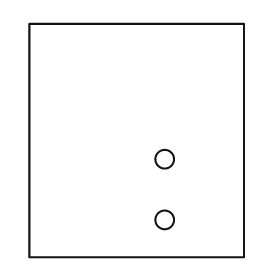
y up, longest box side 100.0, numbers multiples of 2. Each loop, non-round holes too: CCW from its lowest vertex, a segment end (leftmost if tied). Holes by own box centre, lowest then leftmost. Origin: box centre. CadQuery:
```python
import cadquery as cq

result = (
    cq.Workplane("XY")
    .moveTo(-46.0, -50.0)
    .lineTo(46.0, -50.0)
    .lineTo(46.0, 50.0)
    .lineTo(-46.0, 50.0)
    .close()
    .moveTo(12.0, -34.0)
    .circle(4.0)
    .moveTo(12.0, -8.0)
    .circle(4.0)
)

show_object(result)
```